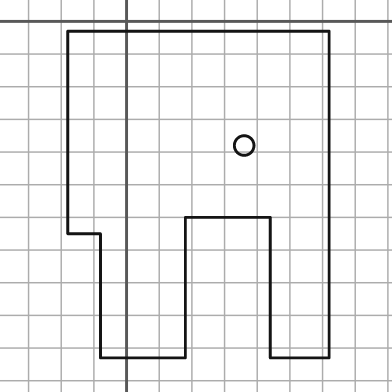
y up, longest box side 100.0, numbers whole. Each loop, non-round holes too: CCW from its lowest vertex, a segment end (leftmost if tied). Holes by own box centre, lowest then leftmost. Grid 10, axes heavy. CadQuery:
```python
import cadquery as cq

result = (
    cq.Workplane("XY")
    .moveTo(-8.0, -103.0)
    .lineTo(18.0, -103.0)
    .lineTo(18.0, -60.0)
    .lineTo(44.0, -60.0)
    .lineTo(44.0, -103.0)
    .lineTo(62.0, -103.0)
    .lineTo(62.0, -3.0)
    .lineTo(-18.0, -3.0)
    .lineTo(-18.0, -65.0)
    .lineTo(-8.0, -65.0)
    .close()
    .moveTo(36.0, -38.0)
    .circle(3.0)
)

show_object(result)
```